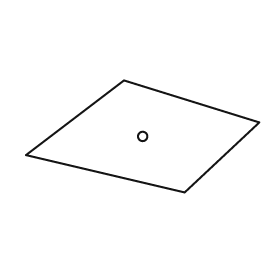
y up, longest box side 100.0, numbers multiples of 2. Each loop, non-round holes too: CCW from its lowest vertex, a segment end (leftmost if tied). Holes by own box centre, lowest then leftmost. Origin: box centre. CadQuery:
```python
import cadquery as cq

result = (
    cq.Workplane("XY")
    .moveTo(18.0, -24.0)
    .lineTo(50.0, 6.0)
    .lineTo(-8.0, 24.0)
    .lineTo(-50.0, -8.0)
    .close()
    .moveTo(0.0, 0.0)
    .circle(2.0)
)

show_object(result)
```